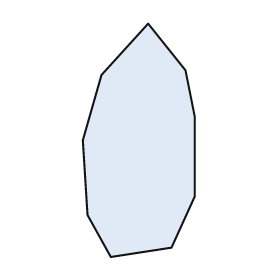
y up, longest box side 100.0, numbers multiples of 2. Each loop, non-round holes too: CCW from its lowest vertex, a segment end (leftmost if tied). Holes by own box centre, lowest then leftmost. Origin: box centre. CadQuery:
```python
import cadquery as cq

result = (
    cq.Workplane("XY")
    .moveTo(-12.0, -50.0)
    .lineTo(14.0, -46.0)
    .lineTo(24.0, -24.0)
    .lineTo(24.0, 10.0)
    .lineTo(20.0, 30.0)
    .lineTo(4.0, 50.0)
    .lineTo(-16.0, 28.0)
    .lineTo(-24.0, 0.0)
    .lineTo(-22.0, -32.0)
    .close()
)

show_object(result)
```